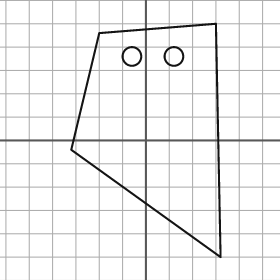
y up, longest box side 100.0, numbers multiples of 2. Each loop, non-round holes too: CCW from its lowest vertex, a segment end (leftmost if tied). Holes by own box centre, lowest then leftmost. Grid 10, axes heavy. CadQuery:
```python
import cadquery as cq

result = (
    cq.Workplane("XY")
    .moveTo(32.0, -50.0)
    .lineTo(30.0, 50.0)
    .lineTo(-20.0, 46.0)
    .lineTo(-32.0, -4.0)
    .close()
    .moveTo(-6.0, 36.0)
    .circle(4.0)
    .moveTo(12.0, 36.0)
    .circle(4.0)
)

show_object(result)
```